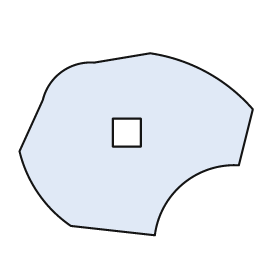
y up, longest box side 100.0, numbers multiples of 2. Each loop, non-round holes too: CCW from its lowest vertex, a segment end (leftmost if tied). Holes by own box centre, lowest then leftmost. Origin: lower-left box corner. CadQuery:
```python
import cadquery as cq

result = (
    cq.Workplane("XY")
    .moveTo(58.0, 0.0)
    .threePointArc((70.0, 22.0), (94.0, 30.0))
    .lineTo(100.0, 54.0)
    .threePointArc((80.0, 70.0), (56.0, 78.0))
    .lineTo(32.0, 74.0)
    .threePointArc((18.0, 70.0), (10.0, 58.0))
    .lineTo(0.0, 36.0)
    .threePointArc((8.0, 18.0), (22.0, 4.0))
    .close()
    .moveTo(40.0, 38.0)
    .lineTo(52.0, 38.0)
    .lineTo(52.0, 50.0)
    .lineTo(40.0, 50.0)
    .close()
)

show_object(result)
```